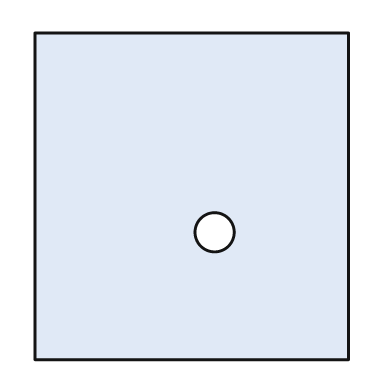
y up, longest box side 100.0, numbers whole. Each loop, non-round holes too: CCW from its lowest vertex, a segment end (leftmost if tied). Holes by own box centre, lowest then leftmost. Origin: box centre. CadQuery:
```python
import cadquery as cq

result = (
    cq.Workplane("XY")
    .moveTo(-48.0, -50.0)
    .lineTo(48.0, -50.0)
    .lineTo(48.0, 50.0)
    .lineTo(-48.0, 50.0)
    .close()
    .moveTo(7.0, -11.0)
    .circle(6.0)
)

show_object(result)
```